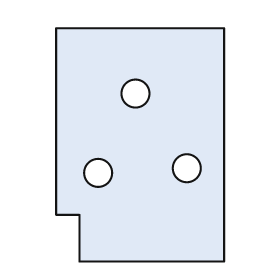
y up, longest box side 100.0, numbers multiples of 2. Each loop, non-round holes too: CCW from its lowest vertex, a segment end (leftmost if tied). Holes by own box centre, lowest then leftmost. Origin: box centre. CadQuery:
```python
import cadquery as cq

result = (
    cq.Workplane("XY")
    .moveTo(-26.0, -50.0)
    .lineTo(36.0, -50.0)
    .lineTo(36.0, 50.0)
    .lineTo(-36.0, 50.0)
    .lineTo(-36.0, -30.0)
    .lineTo(-26.0, -30.0)
    .close()
    .moveTo(-18.0, -12.0)
    .circle(6.0)
    .moveTo(20.0, -10.0)
    .circle(6.0)
    .moveTo(-2.0, 22.0)
    .circle(6.0)
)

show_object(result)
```